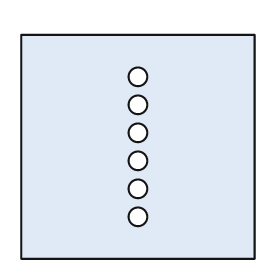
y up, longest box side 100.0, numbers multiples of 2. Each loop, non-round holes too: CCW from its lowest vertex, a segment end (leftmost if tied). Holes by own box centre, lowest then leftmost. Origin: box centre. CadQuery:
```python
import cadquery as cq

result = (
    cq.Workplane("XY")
    .moveTo(-50.0, -48.0)
    .lineTo(50.0, -48.0)
    .lineTo(50.0, 48.0)
    .lineTo(-50.0, 48.0)
    .close()
    .moveTo(0.0, -30.0)
    .circle(4.0)
    .moveTo(0.0, -18.0)
    .circle(4.0)
    .moveTo(0.0, -6.0)
    .circle(4.0)
    .moveTo(0.0, 6.0)
    .circle(4.0)
    .moveTo(0.0, 18.0)
    .circle(4.0)
    .moveTo(0.0, 30.0)
    .circle(4.0)
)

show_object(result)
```